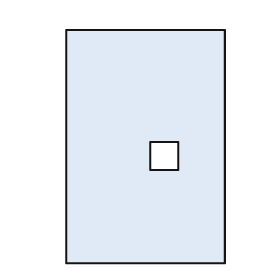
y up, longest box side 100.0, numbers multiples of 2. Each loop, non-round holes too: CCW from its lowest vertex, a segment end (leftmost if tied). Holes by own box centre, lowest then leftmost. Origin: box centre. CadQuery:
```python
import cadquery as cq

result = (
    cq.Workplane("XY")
    .moveTo(-34.0, -50.0)
    .lineTo(34.0, -50.0)
    .lineTo(34.0, 50.0)
    .lineTo(-34.0, 50.0)
    .close()
    .moveTo(2.0, -10.0)
    .lineTo(14.0, -10.0)
    .lineTo(14.0, 2.0)
    .lineTo(2.0, 2.0)
    .close()
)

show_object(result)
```